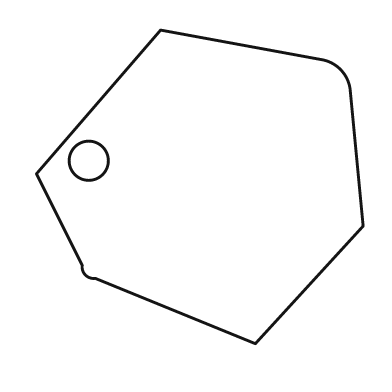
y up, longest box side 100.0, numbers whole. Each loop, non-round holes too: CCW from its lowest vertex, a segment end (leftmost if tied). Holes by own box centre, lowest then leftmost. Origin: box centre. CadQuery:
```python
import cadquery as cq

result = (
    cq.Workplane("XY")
    .moveTo(17.0, -48.0)
    .lineTo(50.0, -12.0)
    .lineTo(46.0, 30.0)
    .threePointArc((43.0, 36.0), (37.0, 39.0))
    .lineTo(-12.0, 48.0)
    .lineTo(-50.0, 4.0)
    .lineTo(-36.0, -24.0)
    .threePointArc((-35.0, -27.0), (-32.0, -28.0))
    .close()
    .moveTo(-34.0, 8.0)
    .circle(6.0)
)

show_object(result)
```